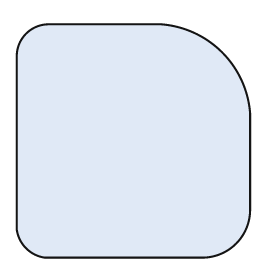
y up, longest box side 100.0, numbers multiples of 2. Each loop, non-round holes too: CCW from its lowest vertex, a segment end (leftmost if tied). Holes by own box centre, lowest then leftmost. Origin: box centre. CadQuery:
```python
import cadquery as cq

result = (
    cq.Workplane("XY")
    .moveTo(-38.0, -50.0)
    .lineTo(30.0, -50.0)
    .threePointArc((44.0, -44.0), (50.0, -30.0))
    .lineTo(50.0, 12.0)
    .threePointArc((38.0, 38.0), (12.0, 50.0))
    .lineTo(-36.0, 50.0)
    .threePointArc((-46.0, 46.0), (-50.0, 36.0))
    .lineTo(-50.0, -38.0)
    .threePointArc((-46.0, -46.0), (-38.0, -50.0))
    .close()
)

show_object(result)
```